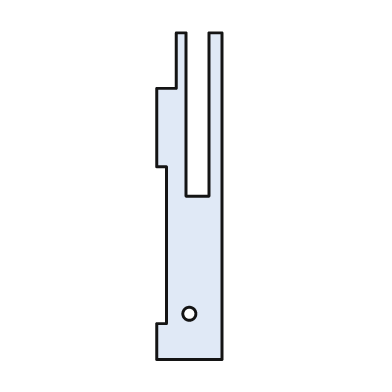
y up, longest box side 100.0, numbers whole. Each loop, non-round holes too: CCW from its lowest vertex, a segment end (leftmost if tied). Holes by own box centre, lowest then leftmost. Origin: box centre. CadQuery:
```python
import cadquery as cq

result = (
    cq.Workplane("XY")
    .moveTo(-10.0, -50.0)
    .lineTo(10.0, -50.0)
    .lineTo(10.0, 50.0)
    .lineTo(6.0, 50.0)
    .lineTo(6.0, 0.0)
    .lineTo(-1.0, 0.0)
    .lineTo(-1.0, 50.0)
    .lineTo(-4.0, 50.0)
    .lineTo(-4.0, 33.0)
    .lineTo(-10.0, 33.0)
    .lineTo(-10.0, 9.0)
    .lineTo(-7.0, 9.0)
    .lineTo(-7.0, -39.0)
    .lineTo(-10.0, -39.0)
    .close()
    .moveTo(0.0, -36.0)
    .circle(2.0)
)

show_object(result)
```